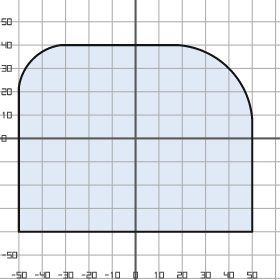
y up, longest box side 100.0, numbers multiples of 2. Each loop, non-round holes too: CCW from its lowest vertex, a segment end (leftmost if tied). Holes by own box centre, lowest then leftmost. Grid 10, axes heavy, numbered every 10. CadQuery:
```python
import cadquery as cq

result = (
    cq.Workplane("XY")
    .moveTo(-50.0, -40.0)
    .lineTo(50.0, -40.0)
    .lineTo(50.0, 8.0)
    .threePointArc((40.0, 30.0), (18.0, 40.0))
    .lineTo(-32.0, 40.0)
    .threePointArc((-44.0, 34.0), (-50.0, 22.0))
    .close()
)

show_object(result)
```